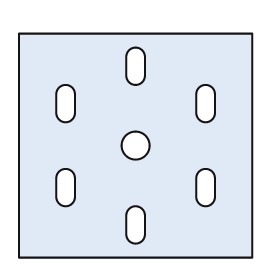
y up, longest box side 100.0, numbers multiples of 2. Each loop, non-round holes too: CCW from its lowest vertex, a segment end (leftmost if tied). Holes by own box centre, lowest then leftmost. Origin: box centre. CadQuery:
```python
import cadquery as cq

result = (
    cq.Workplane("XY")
    .moveTo(-50.0, -48.0)
    .lineTo(50.0, -48.0)
    .lineTo(50.0, 48.0)
    .lineTo(-50.0, 48.0)
    .close()
    .moveTo(-4.0, -38.0)
    .threePointArc((0.0, -42.0), (4.0, -38.0))
    .lineTo(4.0, -30.0)
    .threePointArc((0.0, -26.0), (-4.0, -30.0))
    .close()
    .moveTo(-34.0, -22.0)
    .threePointArc((-30.0, -26.0), (-26.0, -22.0))
    .lineTo(-26.0, -14.0)
    .threePointArc((-30.0, -10.0), (-34.0, -14.0))
    .close()
    .moveTo(26.0, -22.0)
    .threePointArc((30.0, -26.0), (34.0, -22.0))
    .lineTo(34.0, -14.0)
    .threePointArc((30.0, -10.0), (26.0, -14.0))
    .close()
    .moveTo(0.0, 0.0)
    .circle(6.0)
    .moveTo(-34.0, 14.0)
    .threePointArc((-30.0, 10.0), (-26.0, 14.0))
    .lineTo(-26.0, 22.0)
    .threePointArc((-30.0, 26.0), (-34.0, 22.0))
    .close()
    .moveTo(26.0, 14.0)
    .threePointArc((30.0, 10.0), (34.0, 14.0))
    .lineTo(34.0, 22.0)
    .threePointArc((30.0, 26.0), (26.0, 22.0))
    .close()
    .moveTo(-4.0, 30.0)
    .threePointArc((0.0, 26.0), (4.0, 30.0))
    .lineTo(4.0, 38.0)
    .threePointArc((0.0, 42.0), (-4.0, 38.0))
    .close()
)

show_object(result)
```